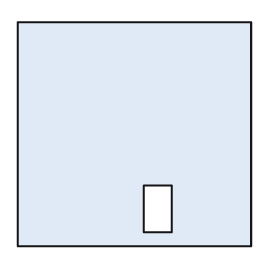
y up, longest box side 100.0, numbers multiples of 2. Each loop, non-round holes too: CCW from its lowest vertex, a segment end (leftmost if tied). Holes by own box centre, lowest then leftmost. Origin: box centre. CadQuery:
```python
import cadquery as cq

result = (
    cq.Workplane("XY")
    .moveTo(-50.0, -48.0)
    .lineTo(50.0, -48.0)
    .lineTo(50.0, 48.0)
    .lineTo(-50.0, 48.0)
    .close()
    .moveTo(4.0, -42.0)
    .lineTo(16.0, -42.0)
    .lineTo(16.0, -22.0)
    .lineTo(4.0, -22.0)
    .close()
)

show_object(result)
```